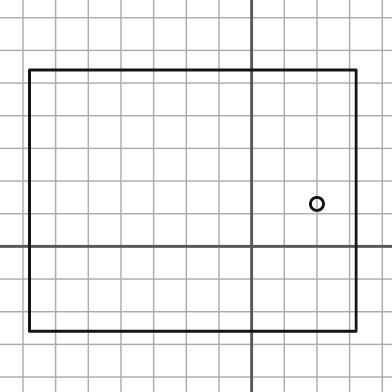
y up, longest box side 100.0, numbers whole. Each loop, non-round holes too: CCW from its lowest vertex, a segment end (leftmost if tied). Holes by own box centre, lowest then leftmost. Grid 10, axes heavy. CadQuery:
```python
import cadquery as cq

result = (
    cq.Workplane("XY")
    .moveTo(-68.0, -26.0)
    .lineTo(32.0, -26.0)
    .lineTo(32.0, 54.0)
    .lineTo(-68.0, 54.0)
    .close()
    .moveTo(20.0, 13.0)
    .circle(2.0)
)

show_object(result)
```